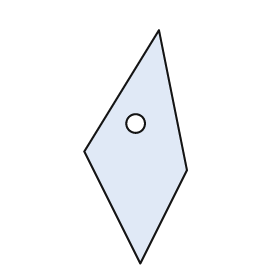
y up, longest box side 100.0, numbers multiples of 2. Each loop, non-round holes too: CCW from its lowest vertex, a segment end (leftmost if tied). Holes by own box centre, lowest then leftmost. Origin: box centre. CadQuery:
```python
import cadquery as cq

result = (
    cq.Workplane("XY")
    .moveTo(2.0, -50.0)
    .lineTo(22.0, -10.0)
    .lineTo(10.0, 50.0)
    .lineTo(-22.0, -2.0)
    .close()
    .moveTo(0.0, 10.0)
    .circle(4.0)
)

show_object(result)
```